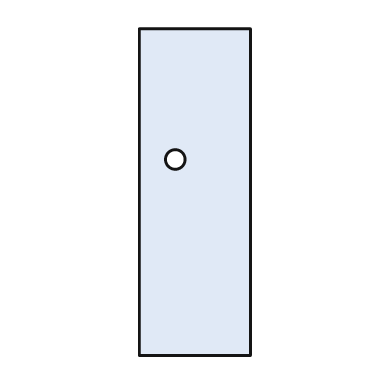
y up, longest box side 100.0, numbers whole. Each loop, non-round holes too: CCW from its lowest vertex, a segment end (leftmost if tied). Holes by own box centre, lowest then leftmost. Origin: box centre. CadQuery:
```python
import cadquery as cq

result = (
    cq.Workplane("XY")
    .moveTo(-17.0, -50.0)
    .lineTo(17.0, -50.0)
    .lineTo(17.0, 50.0)
    .lineTo(-17.0, 50.0)
    .close()
    .moveTo(-6.0, 10.0)
    .circle(3.0)
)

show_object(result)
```